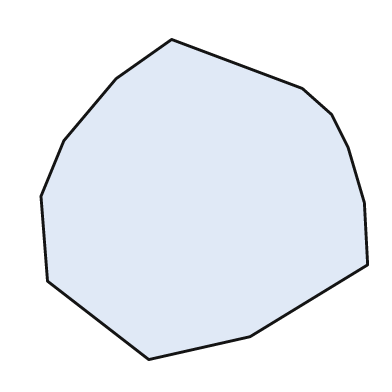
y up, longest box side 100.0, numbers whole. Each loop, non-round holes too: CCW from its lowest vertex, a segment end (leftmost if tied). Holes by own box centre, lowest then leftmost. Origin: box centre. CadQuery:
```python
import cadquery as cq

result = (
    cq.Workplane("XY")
    .moveTo(-17.0, -49.0)
    .lineTo(14.0, -42.0)
    .lineTo(50.0, -20.0)
    .lineTo(49.0, -1.0)
    .lineTo(44.0, 16.0)
    .lineTo(39.0, 26.0)
    .lineTo(30.0, 34.0)
    .lineTo(-10.0, 49.0)
    .lineTo(-27.0, 37.0)
    .lineTo(-43.0, 18.0)
    .lineTo(-50.0, 1.0)
    .lineTo(-48.0, -25.0)
    .close()
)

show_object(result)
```